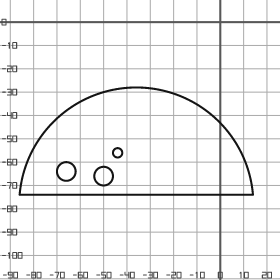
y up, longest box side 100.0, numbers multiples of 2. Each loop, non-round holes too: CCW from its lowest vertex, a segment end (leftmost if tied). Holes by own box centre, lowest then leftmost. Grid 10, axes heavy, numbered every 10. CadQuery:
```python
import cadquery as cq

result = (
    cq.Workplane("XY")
    .moveTo(-86.0, -74.0)
    .lineTo(14.0, -74.0)
    .threePointArc((-36.0, -28.0), (-86.0, -74.0))
    .close()
    .moveTo(-50.0, -66.0)
    .circle(4.0)
    .moveTo(-66.0, -64.0)
    .circle(4.0)
    .moveTo(-44.0, -56.0)
    .circle(2.0)
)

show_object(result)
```